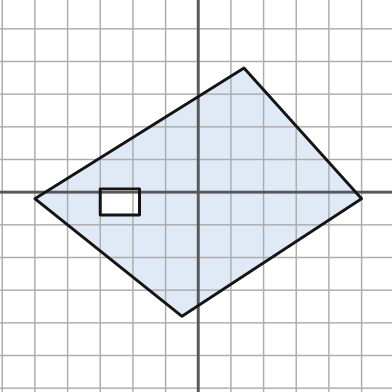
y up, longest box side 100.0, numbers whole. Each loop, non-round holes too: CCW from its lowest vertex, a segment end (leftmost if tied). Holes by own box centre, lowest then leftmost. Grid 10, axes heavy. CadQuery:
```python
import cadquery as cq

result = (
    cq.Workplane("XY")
    .moveTo(-5.0, -38.0)
    .lineTo(50.0, -2.0)
    .lineTo(14.0, 38.0)
    .lineTo(-50.0, -2.0)
    .close()
    .moveTo(-30.0, -7.0)
    .lineTo(-18.0, -7.0)
    .lineTo(-18.0, 1.0)
    .lineTo(-30.0, 1.0)
    .close()
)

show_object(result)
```